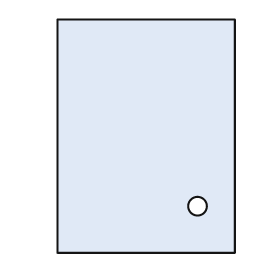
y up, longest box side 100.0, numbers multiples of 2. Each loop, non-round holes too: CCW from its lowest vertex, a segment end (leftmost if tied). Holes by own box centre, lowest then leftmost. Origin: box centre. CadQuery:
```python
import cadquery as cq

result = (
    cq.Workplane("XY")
    .moveTo(-38.0, -50.0)
    .lineTo(38.0, -50.0)
    .lineTo(38.0, 50.0)
    .lineTo(-38.0, 50.0)
    .close()
    .moveTo(22.0, -30.0)
    .circle(4.0)
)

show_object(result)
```